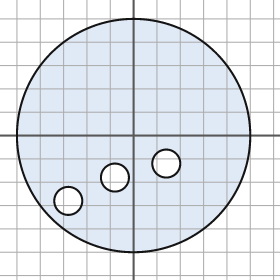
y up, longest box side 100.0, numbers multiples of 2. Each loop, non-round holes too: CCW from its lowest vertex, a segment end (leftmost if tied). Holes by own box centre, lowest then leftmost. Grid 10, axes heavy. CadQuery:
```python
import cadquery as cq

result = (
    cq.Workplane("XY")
    .moveTo(0.0, 0.0)
    .circle(50.0)
    .moveTo(-28.0, -28.0)
    .circle(6.0)
    .moveTo(-8.0, -18.0)
    .circle(6.0)
    .moveTo(14.0, -12.0)
    .circle(6.0)
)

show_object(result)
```